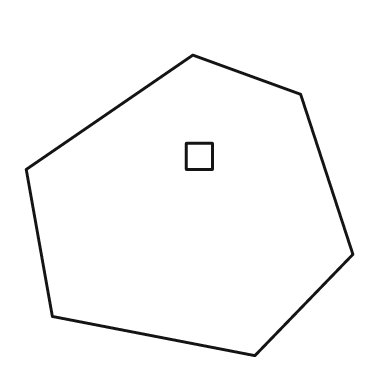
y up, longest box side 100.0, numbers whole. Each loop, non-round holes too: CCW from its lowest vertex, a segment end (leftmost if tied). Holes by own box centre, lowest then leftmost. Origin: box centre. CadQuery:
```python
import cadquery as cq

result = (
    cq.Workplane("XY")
    .moveTo(20.0, -46.0)
    .lineTo(50.0, -15.0)
    .lineTo(34.0, 34.0)
    .lineTo(1.0, 46.0)
    .lineTo(-50.0, 11.0)
    .lineTo(-42.0, -34.0)
    .close()
    .moveTo(-1.0, 11.0)
    .lineTo(7.0, 11.0)
    .lineTo(7.0, 19.0)
    .lineTo(-1.0, 19.0)
    .close()
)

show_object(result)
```